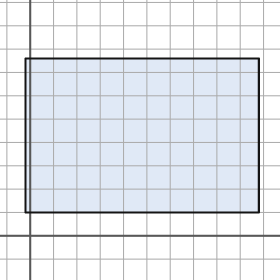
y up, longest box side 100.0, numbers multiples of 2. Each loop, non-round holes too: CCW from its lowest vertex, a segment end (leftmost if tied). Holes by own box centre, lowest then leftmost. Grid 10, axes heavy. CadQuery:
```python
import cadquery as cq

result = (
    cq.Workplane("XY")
    .moveTo(-2.0, 10.0)
    .lineTo(98.0, 10.0)
    .lineTo(98.0, 76.0)
    .lineTo(-2.0, 76.0)
    .close()
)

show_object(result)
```